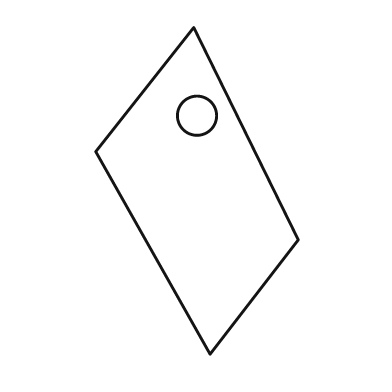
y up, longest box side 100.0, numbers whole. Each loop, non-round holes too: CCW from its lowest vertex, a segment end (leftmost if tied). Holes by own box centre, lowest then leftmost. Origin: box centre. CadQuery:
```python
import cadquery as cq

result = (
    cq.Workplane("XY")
    .moveTo(4.0, -50.0)
    .lineTo(31.0, -15.0)
    .lineTo(-1.0, 50.0)
    .lineTo(-31.0, 12.0)
    .close()
    .moveTo(0.0, 23.0)
    .circle(6.0)
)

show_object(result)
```